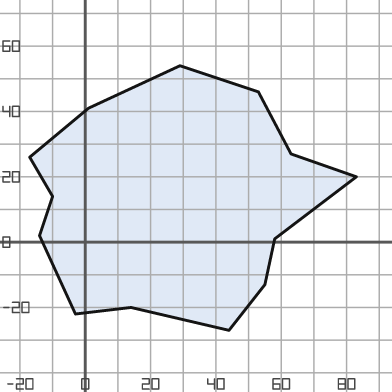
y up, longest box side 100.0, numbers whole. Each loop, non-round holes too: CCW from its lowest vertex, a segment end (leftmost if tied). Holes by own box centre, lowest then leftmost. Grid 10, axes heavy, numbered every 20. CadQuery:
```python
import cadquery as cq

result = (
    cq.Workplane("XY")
    .moveTo(44.0, -27.0)
    .lineTo(55.0, -13.0)
    .lineTo(58.0, 1.0)
    .lineTo(83.0, 20.0)
    .lineTo(63.0, 27.0)
    .lineTo(53.0, 46.0)
    .lineTo(29.0, 54.0)
    .lineTo(1.0, 41.0)
    .lineTo(-17.0, 26.0)
    .lineTo(-10.0, 14.0)
    .lineTo(-14.0, 2.0)
    .lineTo(-3.0, -22.0)
    .lineTo(14.0, -20.0)
    .close()
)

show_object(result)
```